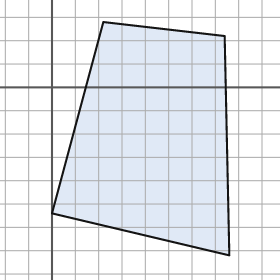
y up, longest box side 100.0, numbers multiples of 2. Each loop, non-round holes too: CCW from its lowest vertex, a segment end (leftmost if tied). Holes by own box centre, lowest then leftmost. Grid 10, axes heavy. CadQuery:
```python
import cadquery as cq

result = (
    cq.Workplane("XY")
    .moveTo(76.0, -72.0)
    .lineTo(74.0, 22.0)
    .lineTo(22.0, 28.0)
    .lineTo(0.0, -54.0)
    .close()
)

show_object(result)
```